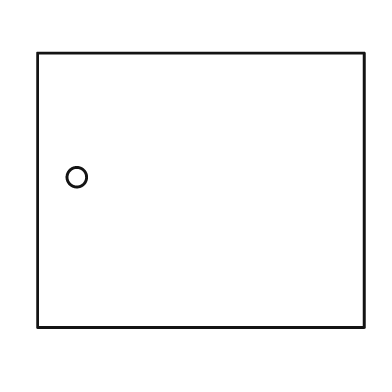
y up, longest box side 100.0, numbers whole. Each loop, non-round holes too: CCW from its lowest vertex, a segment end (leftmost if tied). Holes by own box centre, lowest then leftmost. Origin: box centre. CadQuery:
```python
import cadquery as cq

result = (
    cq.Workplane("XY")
    .moveTo(-50.0, -42.0)
    .lineTo(50.0, -42.0)
    .lineTo(50.0, 42.0)
    .lineTo(-50.0, 42.0)
    .close()
    .moveTo(-38.0, 4.0)
    .circle(3.0)
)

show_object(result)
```